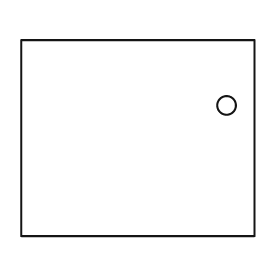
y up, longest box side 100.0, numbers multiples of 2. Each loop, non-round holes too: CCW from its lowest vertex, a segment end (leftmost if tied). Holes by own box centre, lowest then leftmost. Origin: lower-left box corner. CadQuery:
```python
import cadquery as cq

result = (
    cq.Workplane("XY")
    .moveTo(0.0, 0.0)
    .lineTo(100.0, 0.0)
    .lineTo(100.0, 84.0)
    .lineTo(0.0, 84.0)
    .close()
    .moveTo(88.0, 56.0)
    .circle(4.0)
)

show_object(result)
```